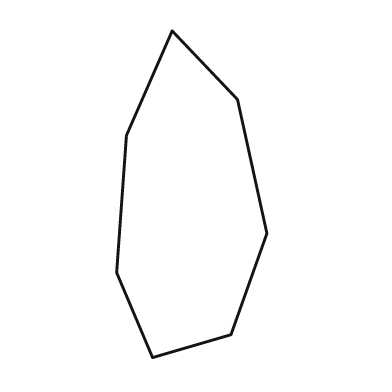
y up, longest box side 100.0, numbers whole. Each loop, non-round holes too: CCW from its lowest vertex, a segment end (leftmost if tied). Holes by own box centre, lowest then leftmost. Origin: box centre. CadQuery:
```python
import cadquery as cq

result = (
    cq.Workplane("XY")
    .moveTo(-12.0, -50.0)
    .lineTo(12.0, -43.0)
    .lineTo(23.0, -12.0)
    .lineTo(14.0, 29.0)
    .lineTo(-6.0, 50.0)
    .lineTo(-20.0, 18.0)
    .lineTo(-23.0, -24.0)
    .close()
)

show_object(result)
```